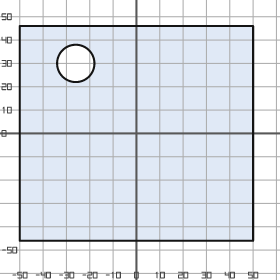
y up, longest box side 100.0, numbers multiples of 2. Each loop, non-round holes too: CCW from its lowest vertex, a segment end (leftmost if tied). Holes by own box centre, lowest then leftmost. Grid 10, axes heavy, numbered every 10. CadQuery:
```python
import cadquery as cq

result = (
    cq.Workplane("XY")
    .moveTo(-50.0, -46.0)
    .lineTo(50.0, -46.0)
    .lineTo(50.0, 46.0)
    .lineTo(-50.0, 46.0)
    .close()
    .moveTo(-26.0, 30.0)
    .circle(8.0)
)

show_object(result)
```